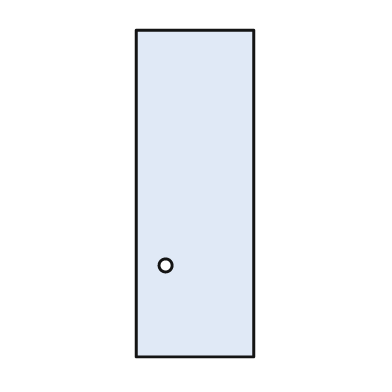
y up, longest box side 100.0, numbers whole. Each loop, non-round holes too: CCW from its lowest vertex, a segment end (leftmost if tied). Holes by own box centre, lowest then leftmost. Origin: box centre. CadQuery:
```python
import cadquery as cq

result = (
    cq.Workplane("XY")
    .moveTo(-18.0, -50.0)
    .lineTo(18.0, -50.0)
    .lineTo(18.0, 50.0)
    .lineTo(-18.0, 50.0)
    .close()
    .moveTo(-9.0, -22.0)
    .circle(2.0)
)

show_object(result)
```